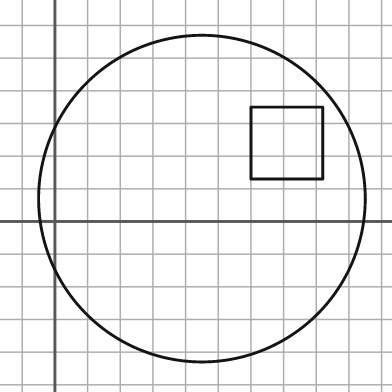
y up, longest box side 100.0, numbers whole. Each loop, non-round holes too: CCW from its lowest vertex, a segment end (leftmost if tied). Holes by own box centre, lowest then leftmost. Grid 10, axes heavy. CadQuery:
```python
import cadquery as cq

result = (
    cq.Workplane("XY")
    .moveTo(45.0, 7.0)
    .circle(50.0)
    .moveTo(60.0, 13.0)
    .lineTo(82.0, 13.0)
    .lineTo(82.0, 35.0)
    .lineTo(60.0, 35.0)
    .close()
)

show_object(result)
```